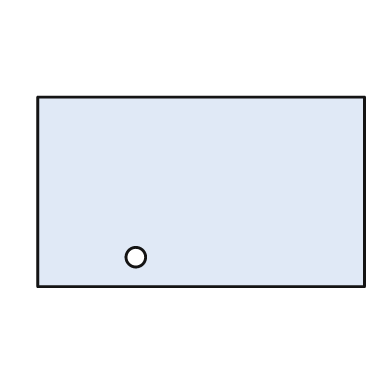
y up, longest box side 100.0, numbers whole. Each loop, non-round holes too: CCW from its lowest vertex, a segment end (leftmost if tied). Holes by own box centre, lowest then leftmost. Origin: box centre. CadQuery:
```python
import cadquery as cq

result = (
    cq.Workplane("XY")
    .moveTo(-50.0, -29.0)
    .lineTo(50.0, -29.0)
    .lineTo(50.0, 29.0)
    .lineTo(-50.0, 29.0)
    .close()
    .moveTo(-20.0, -20.0)
    .circle(3.0)
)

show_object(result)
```